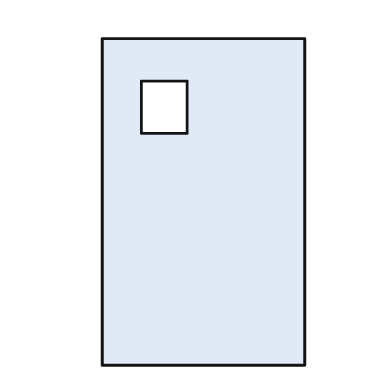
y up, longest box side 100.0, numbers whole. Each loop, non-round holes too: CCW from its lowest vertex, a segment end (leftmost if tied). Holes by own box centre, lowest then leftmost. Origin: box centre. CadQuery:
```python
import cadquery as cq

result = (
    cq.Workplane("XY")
    .moveTo(-31.0, -50.0)
    .lineTo(31.0, -50.0)
    .lineTo(31.0, 50.0)
    .lineTo(-31.0, 50.0)
    .close()
    .moveTo(-19.0, 21.0)
    .lineTo(-5.0, 21.0)
    .lineTo(-5.0, 37.0)
    .lineTo(-19.0, 37.0)
    .close()
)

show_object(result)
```